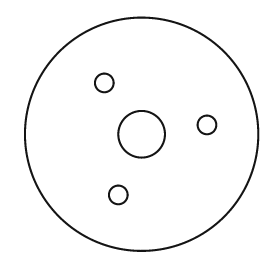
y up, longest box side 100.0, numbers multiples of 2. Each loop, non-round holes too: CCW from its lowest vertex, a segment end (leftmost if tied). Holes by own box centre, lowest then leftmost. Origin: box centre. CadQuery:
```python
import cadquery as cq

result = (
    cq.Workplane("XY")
    .moveTo(0.0, 0.0)
    .circle(50.0)
    .moveTo(-10.0, -26.0)
    .circle(4.0)
    .moveTo(0.0, 0.0)
    .circle(10.0)
    .moveTo(28.0, 4.0)
    .circle(4.0)
    .moveTo(-16.0, 22.0)
    .circle(4.0)
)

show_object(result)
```